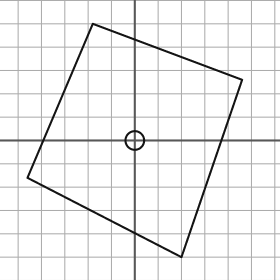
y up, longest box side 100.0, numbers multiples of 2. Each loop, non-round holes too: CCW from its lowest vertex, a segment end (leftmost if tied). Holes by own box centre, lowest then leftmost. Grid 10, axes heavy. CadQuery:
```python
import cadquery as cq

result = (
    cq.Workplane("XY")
    .moveTo(20.0, -50.0)
    .lineTo(46.0, 26.0)
    .lineTo(-18.0, 50.0)
    .lineTo(-46.0, -16.0)
    .close()
    .moveTo(0.0, 0.0)
    .circle(4.0)
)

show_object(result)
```